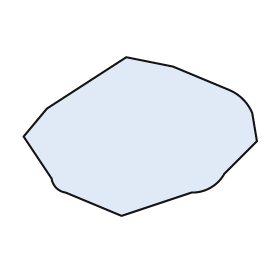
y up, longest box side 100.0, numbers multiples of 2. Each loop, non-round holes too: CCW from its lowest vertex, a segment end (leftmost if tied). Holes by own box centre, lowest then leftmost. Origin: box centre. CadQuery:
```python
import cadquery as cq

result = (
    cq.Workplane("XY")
    .moveTo(-8.0, -34.0)
    .lineTo(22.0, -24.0)
    .threePointArc((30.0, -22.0), (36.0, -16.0))
    .lineTo(50.0, -2.0)
    .lineTo(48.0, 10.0)
    .threePointArc((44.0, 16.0), (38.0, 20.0))
    .lineTo(14.0, 30.0)
    .lineTo(-6.0, 34.0)
    .lineTo(-40.0, 12.0)
    .lineTo(-50.0, 0.0)
    .lineTo(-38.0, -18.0)
    .threePointArc((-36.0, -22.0), (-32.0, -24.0))
    .close()
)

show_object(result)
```